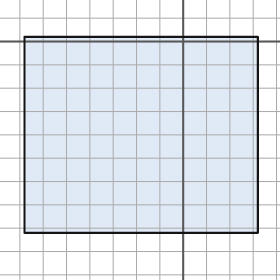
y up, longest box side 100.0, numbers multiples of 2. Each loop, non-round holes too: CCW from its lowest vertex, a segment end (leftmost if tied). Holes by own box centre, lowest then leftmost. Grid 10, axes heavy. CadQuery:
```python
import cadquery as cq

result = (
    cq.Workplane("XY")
    .moveTo(-68.0, -82.0)
    .lineTo(32.0, -82.0)
    .lineTo(32.0, 2.0)
    .lineTo(-68.0, 2.0)
    .close()
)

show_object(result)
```